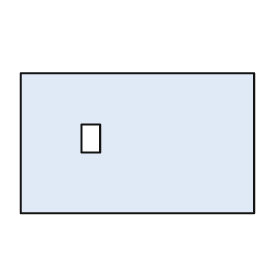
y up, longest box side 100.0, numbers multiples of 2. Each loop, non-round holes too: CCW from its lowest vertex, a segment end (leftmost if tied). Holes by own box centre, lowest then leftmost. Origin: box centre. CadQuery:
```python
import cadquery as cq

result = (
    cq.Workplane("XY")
    .moveTo(-50.0, -30.0)
    .lineTo(50.0, -30.0)
    .lineTo(50.0, 30.0)
    .lineTo(-50.0, 30.0)
    .close()
    .moveTo(-24.0, -4.0)
    .lineTo(-16.0, -4.0)
    .lineTo(-16.0, 8.0)
    .lineTo(-24.0, 8.0)
    .close()
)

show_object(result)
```